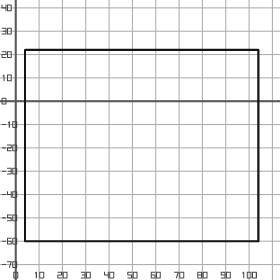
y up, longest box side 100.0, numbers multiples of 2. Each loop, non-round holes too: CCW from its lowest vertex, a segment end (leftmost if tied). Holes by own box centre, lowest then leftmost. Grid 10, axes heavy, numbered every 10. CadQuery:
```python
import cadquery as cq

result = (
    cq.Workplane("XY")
    .moveTo(4.0, -60.0)
    .lineTo(104.0, -60.0)
    .lineTo(104.0, 22.0)
    .lineTo(4.0, 22.0)
    .close()
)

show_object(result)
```